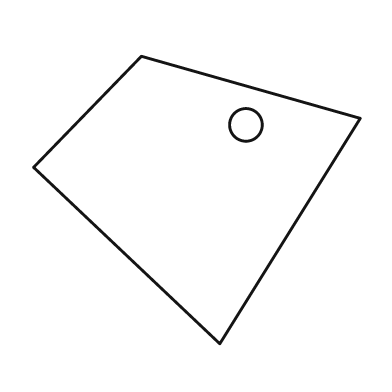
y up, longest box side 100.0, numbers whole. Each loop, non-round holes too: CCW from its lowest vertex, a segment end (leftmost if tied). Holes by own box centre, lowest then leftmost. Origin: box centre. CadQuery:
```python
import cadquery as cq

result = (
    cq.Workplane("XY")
    .moveTo(7.0, -44.0)
    .lineTo(50.0, 25.0)
    .lineTo(-17.0, 44.0)
    .lineTo(-50.0, 10.0)
    .close()
    .moveTo(15.0, 23.0)
    .circle(5.0)
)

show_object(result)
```